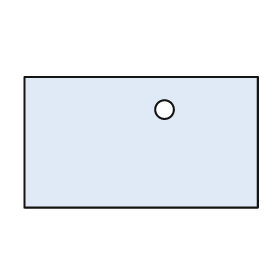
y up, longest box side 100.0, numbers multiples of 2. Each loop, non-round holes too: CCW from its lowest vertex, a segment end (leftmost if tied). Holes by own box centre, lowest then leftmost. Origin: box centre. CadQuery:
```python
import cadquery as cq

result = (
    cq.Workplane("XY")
    .moveTo(-50.0, -28.0)
    .lineTo(50.0, -28.0)
    .lineTo(50.0, 28.0)
    .lineTo(-50.0, 28.0)
    .close()
    .moveTo(10.0, 14.0)
    .circle(4.0)
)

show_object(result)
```